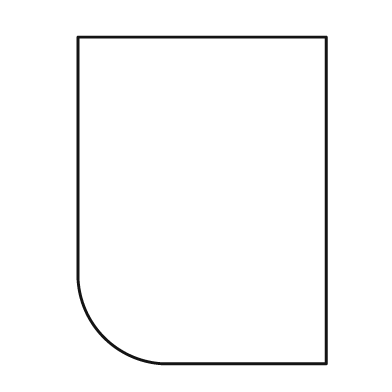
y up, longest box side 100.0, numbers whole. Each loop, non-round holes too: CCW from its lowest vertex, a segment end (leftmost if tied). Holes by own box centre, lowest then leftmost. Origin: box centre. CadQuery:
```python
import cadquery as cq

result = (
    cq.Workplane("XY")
    .moveTo(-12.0, -50.0)
    .lineTo(38.0, -50.0)
    .lineTo(38.0, 50.0)
    .lineTo(-38.0, 50.0)
    .lineTo(-38.0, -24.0)
    .threePointArc((-30.0, -42.0), (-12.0, -50.0))
    .close()
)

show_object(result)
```